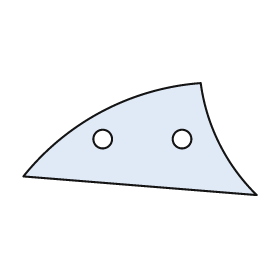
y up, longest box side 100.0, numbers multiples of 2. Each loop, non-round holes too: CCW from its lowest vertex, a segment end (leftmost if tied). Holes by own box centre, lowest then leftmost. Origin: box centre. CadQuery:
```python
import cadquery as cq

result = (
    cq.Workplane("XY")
    .moveTo(50.0, -24.0)
    .threePointArc((34.0, -2.0), (26.0, 24.0))
    .threePointArc((-16.0, 12.0), (-50.0, -16.0))
    .close()
    .moveTo(-16.0, 0.0)
    .circle(4.0)
    .moveTo(18.0, 0.0)
    .circle(4.0)
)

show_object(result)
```